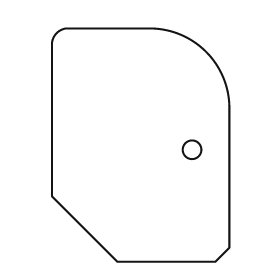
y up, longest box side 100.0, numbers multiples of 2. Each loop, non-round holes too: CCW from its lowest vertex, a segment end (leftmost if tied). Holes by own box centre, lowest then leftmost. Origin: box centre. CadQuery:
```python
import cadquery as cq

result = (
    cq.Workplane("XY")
    .moveTo(-10.0, -50.0)
    .lineTo(32.0, -50.0)
    .lineTo(38.0, -44.0)
    .lineTo(38.0, 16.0)
    .threePointArc((28.0, 40.0), (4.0, 50.0))
    .lineTo(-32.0, 50.0)
    .threePointArc((-36.0, 48.0), (-38.0, 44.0))
    .lineTo(-38.0, -22.0)
    .close()
    .moveTo(22.0, -2.0)
    .circle(4.0)
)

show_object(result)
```